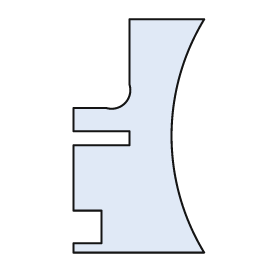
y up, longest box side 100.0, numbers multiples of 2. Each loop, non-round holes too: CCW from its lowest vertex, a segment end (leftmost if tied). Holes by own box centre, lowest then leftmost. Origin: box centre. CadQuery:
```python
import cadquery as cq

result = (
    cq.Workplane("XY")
    .moveTo(-28.0, -50.0)
    .lineTo(28.0, -50.0)
    .threePointArc((14.0, 0.0), (28.0, 50.0))
    .lineTo(-4.0, 50.0)
    .lineTo(-4.0, 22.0)
    .threePointArc((-6.0, 14.0), (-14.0, 12.0))
    .lineTo(-28.0, 12.0)
    .lineTo(-28.0, 2.0)
    .lineTo(-4.0, 2.0)
    .lineTo(-4.0, -4.0)
    .lineTo(-28.0, -4.0)
    .lineTo(-28.0, -32.0)
    .lineTo(-16.0, -32.0)
    .lineTo(-16.0, -46.0)
    .lineTo(-28.0, -46.0)
    .close()
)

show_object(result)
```